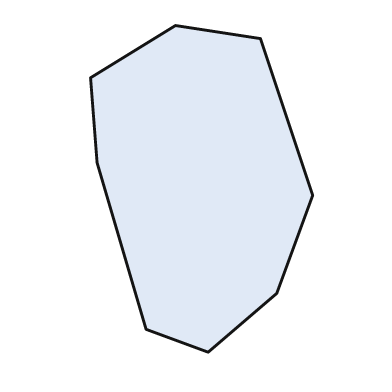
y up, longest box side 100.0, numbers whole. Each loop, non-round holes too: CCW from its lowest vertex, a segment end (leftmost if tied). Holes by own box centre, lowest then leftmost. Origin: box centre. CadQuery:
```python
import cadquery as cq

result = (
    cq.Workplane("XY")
    .moveTo(2.0, -50.0)
    .lineTo(23.0, -32.0)
    .lineTo(34.0, -2.0)
    .lineTo(18.0, 46.0)
    .lineTo(-8.0, 50.0)
    .lineTo(-34.0, 34.0)
    .lineTo(-32.0, 8.0)
    .lineTo(-17.0, -43.0)
    .close()
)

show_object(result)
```